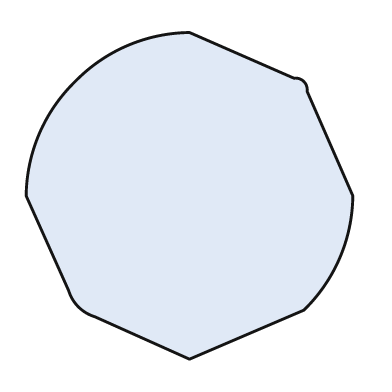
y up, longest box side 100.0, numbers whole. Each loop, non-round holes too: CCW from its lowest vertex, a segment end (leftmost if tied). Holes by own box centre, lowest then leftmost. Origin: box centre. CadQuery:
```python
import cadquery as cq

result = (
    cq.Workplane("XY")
    .moveTo(0.0, -50.0)
    .lineTo(35.0, -35.0)
    .threePointArc((46.0, -19.0), (50.0, 0.0))
    .lineTo(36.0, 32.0)
    .threePointArc((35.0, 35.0), (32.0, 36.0))
    .lineTo(0.0, 50.0)
    .threePointArc((-19.0, 46.0), (-35.0, 35.0))
    .threePointArc((-46.0, 19.0), (-50.0, 0.0))
    .lineTo(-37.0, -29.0)
    .threePointArc((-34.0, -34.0), (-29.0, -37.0))
    .close()
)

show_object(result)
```